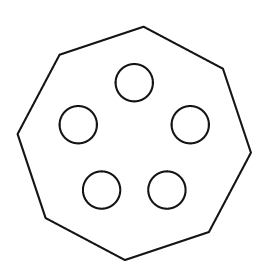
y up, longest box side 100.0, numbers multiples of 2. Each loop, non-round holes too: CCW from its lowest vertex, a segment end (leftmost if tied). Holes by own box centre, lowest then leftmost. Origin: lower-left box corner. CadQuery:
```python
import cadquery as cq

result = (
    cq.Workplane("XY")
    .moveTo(46.0, 0.0)
    .lineTo(82.0, 12.0)
    .lineTo(100.0, 46.0)
    .lineTo(88.0, 82.0)
    .lineTo(54.0, 100.0)
    .lineTo(18.0, 88.0)
    .lineTo(0.0, 54.0)
    .lineTo(12.0, 18.0)
    .close()
    .moveTo(36.0, 30.0)
    .circle(8.0)
    .moveTo(64.0, 30.0)
    .circle(8.0)
    .moveTo(26.0, 58.0)
    .circle(8.0)
    .moveTo(74.0, 58.0)
    .circle(8.0)
    .moveTo(50.0, 76.0)
    .circle(8.0)
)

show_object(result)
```